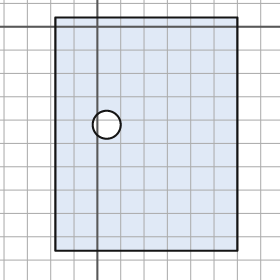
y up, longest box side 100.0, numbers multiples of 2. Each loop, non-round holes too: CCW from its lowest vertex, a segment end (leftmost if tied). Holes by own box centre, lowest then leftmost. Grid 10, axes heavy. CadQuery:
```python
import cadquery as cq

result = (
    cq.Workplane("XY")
    .moveTo(-18.0, -96.0)
    .lineTo(60.0, -96.0)
    .lineTo(60.0, 4.0)
    .lineTo(-18.0, 4.0)
    .close()
    .moveTo(4.0, -42.0)
    .circle(6.0)
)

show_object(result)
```